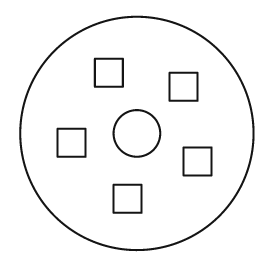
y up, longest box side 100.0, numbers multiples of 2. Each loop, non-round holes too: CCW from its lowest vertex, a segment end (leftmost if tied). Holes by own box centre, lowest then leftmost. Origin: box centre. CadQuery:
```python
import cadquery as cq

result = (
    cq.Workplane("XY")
    .moveTo(0.0, 0.0)
    .circle(50.0)
    .moveTo(-10.0, -34.0)
    .lineTo(2.0, -34.0)
    .lineTo(2.0, -22.0)
    .lineTo(-10.0, -22.0)
    .close()
    .moveTo(20.0, -18.0)
    .lineTo(32.0, -18.0)
    .lineTo(32.0, -6.0)
    .lineTo(20.0, -6.0)
    .close()
    .moveTo(-34.0, -10.0)
    .lineTo(-22.0, -10.0)
    .lineTo(-22.0, 2.0)
    .lineTo(-34.0, 2.0)
    .close()
    .moveTo(0.0, 0.0)
    .circle(10.0)
    .moveTo(14.0, 14.0)
    .lineTo(26.0, 14.0)
    .lineTo(26.0, 26.0)
    .lineTo(14.0, 26.0)
    .close()
    .moveTo(-18.0, 20.0)
    .lineTo(-6.0, 20.0)
    .lineTo(-6.0, 32.0)
    .lineTo(-18.0, 32.0)
    .close()
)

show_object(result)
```